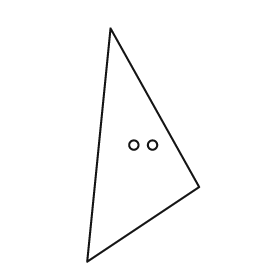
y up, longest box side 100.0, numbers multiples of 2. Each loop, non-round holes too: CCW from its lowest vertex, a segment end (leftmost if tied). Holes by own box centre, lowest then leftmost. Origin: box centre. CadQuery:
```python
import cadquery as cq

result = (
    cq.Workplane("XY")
    .moveTo(-24.0, -50.0)
    .lineTo(24.0, -18.0)
    .lineTo(-14.0, 50.0)
    .close()
    .moveTo(-4.0, 0.0)
    .circle(2.0)
    .moveTo(4.0, 0.0)
    .circle(2.0)
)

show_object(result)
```